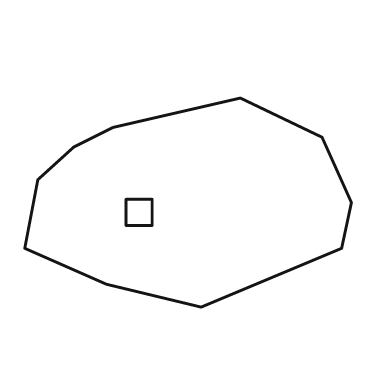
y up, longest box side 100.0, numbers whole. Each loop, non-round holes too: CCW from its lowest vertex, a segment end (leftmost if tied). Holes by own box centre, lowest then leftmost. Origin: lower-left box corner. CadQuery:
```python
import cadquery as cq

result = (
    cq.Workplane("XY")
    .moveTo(54.0, 0.0)
    .lineTo(97.0, 18.0)
    .lineTo(100.0, 32.0)
    .lineTo(91.0, 52.0)
    .lineTo(66.0, 64.0)
    .lineTo(27.0, 55.0)
    .lineTo(15.0, 49.0)
    .lineTo(4.0, 39.0)
    .lineTo(0.0, 18.0)
    .lineTo(25.0, 7.0)
    .close()
    .moveTo(31.0, 25.0)
    .lineTo(39.0, 25.0)
    .lineTo(39.0, 33.0)
    .lineTo(31.0, 33.0)
    .close()
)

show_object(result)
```